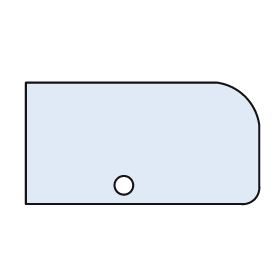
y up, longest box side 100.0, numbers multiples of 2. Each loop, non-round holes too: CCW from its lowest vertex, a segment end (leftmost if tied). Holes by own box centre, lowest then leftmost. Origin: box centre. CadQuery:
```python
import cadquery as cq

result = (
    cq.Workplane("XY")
    .moveTo(-50.0, -26.0)
    .lineTo(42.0, -26.0)
    .threePointArc((48.0, -24.0), (50.0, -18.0))
    .lineTo(50.0, 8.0)
    .threePointArc((44.0, 20.0), (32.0, 26.0))
    .lineTo(-50.0, 26.0)
    .close()
    .moveTo(-8.0, -18.0)
    .circle(4.0)
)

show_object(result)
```